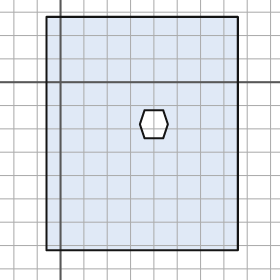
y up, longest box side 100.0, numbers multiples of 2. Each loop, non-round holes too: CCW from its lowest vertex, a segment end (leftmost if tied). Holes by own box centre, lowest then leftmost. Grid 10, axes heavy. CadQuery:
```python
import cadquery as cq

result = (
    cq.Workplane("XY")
    .moveTo(-6.0, -72.0)
    .lineTo(76.0, -72.0)
    .lineTo(76.0, 28.0)
    .lineTo(-6.0, 28.0)
    .close()
    .moveTo(36.0, -24.0)
    .lineTo(44.0, -24.0)
    .lineTo(46.0, -18.0)
    .lineTo(44.0, -12.0)
    .lineTo(36.0, -12.0)
    .lineTo(34.0, -18.0)
    .close()
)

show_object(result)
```